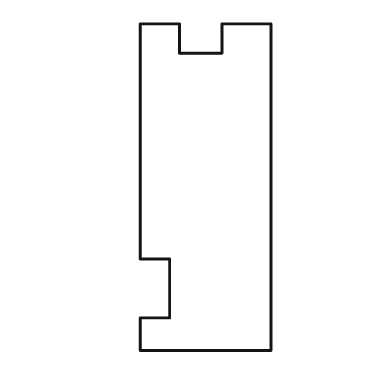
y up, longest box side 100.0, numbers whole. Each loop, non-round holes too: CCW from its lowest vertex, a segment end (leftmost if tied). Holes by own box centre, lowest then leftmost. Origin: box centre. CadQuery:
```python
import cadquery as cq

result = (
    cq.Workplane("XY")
    .moveTo(-20.0, -50.0)
    .lineTo(20.0, -50.0)
    .lineTo(20.0, 50.0)
    .lineTo(5.0, 50.0)
    .lineTo(5.0, 41.0)
    .lineTo(-8.0, 41.0)
    .lineTo(-8.0, 50.0)
    .lineTo(-20.0, 50.0)
    .lineTo(-20.0, -22.0)
    .lineTo(-11.0, -22.0)
    .lineTo(-11.0, -40.0)
    .lineTo(-20.0, -40.0)
    .close()
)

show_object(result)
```